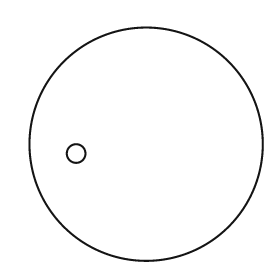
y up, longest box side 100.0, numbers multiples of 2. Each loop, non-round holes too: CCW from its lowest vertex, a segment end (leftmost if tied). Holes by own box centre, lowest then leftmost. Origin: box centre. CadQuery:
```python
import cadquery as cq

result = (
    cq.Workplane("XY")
    .moveTo(0.0, 0.0)
    .circle(50.0)
    .moveTo(-30.0, -4.0)
    .circle(4.0)
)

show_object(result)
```